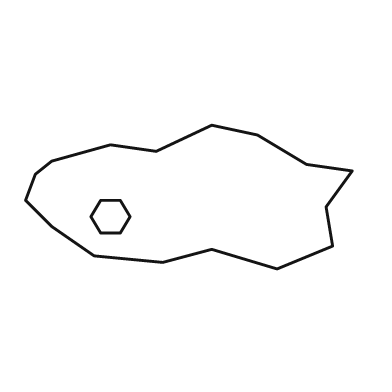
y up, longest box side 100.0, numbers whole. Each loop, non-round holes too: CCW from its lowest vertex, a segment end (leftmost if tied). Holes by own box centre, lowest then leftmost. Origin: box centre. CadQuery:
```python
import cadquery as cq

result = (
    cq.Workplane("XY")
    .moveTo(27.0, -22.0)
    .lineTo(44.0, -15.0)
    .lineTo(42.0, -3.0)
    .lineTo(50.0, 8.0)
    .lineTo(36.0, 10.0)
    .lineTo(21.0, 19.0)
    .lineTo(7.0, 22.0)
    .lineTo(-10.0, 14.0)
    .lineTo(-24.0, 16.0)
    .lineTo(-42.0, 11.0)
    .lineTo(-47.0, 7.0)
    .lineTo(-50.0, -1.0)
    .lineTo(-42.0, -9.0)
    .lineTo(-29.0, -18.0)
    .lineTo(-8.0, -20.0)
    .lineTo(7.0, -16.0)
    .close()
    .moveTo(-27.0, -11.0)
    .lineTo(-21.0, -11.0)
    .lineTo(-18.0, -6.0)
    .lineTo(-21.0, -1.0)
    .lineTo(-27.0, -1.0)
    .lineTo(-30.0, -6.0)
    .close()
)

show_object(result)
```